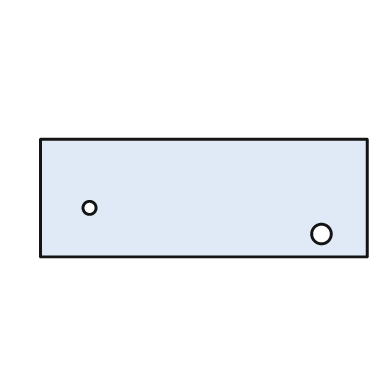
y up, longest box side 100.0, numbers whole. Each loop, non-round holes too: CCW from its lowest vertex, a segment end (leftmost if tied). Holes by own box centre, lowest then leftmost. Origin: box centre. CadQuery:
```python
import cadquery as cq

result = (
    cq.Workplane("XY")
    .moveTo(-50.0, -18.0)
    .lineTo(50.0, -18.0)
    .lineTo(50.0, 18.0)
    .lineTo(-50.0, 18.0)
    .close()
    .moveTo(36.0, -11.0)
    .circle(3.0)
    .moveTo(-35.0, -3.0)
    .circle(2.0)
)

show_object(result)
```